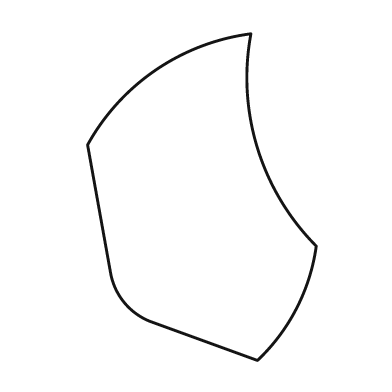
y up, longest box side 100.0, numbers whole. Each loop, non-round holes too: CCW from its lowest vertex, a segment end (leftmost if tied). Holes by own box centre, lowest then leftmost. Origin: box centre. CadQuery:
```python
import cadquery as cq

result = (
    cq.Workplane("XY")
    .moveTo(17.0, -50.0)
    .threePointArc((29.0, -34.0), (35.0, -15.0))
    .threePointArc((17.0, 15.0), (15.0, 50.0))
    .threePointArc((-14.0, 39.0), (-35.0, 16.0))
    .lineTo(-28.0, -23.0)
    .threePointArc((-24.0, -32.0), (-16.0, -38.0))
    .close()
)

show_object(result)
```